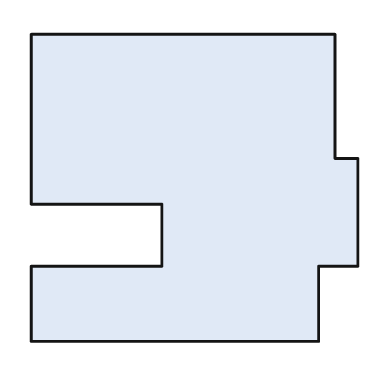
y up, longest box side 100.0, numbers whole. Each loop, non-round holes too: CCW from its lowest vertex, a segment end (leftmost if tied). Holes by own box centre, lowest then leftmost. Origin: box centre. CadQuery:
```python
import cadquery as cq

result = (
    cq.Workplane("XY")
    .moveTo(-50.0, -47.0)
    .lineTo(38.0, -47.0)
    .lineTo(38.0, -24.0)
    .lineTo(50.0, -24.0)
    .lineTo(50.0, 9.0)
    .lineTo(43.0, 9.0)
    .lineTo(43.0, 47.0)
    .lineTo(-50.0, 47.0)
    .lineTo(-50.0, -5.0)
    .lineTo(-10.0, -5.0)
    .lineTo(-10.0, -24.0)
    .lineTo(-50.0, -24.0)
    .close()
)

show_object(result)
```